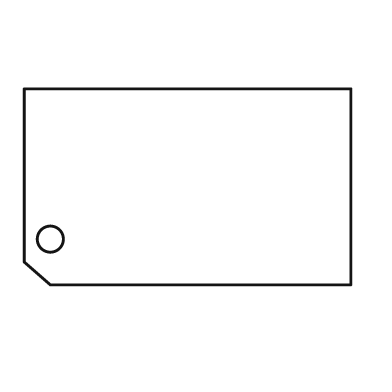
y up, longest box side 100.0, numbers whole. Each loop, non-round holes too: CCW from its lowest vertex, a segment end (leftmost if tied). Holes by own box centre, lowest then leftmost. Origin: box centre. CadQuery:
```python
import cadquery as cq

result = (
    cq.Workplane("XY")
    .moveTo(-42.0, -30.0)
    .lineTo(50.0, -30.0)
    .lineTo(50.0, 30.0)
    .lineTo(-50.0, 30.0)
    .lineTo(-50.0, -23.0)
    .close()
    .moveTo(-42.0, -16.0)
    .circle(4.0)
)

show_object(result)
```